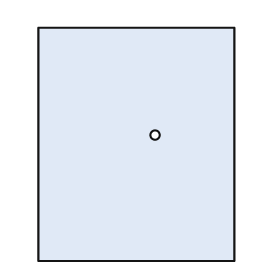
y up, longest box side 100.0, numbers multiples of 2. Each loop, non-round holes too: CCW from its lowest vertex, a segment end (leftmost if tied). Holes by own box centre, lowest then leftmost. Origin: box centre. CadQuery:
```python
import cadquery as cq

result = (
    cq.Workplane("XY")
    .moveTo(-42.0, -50.0)
    .lineTo(42.0, -50.0)
    .lineTo(42.0, 50.0)
    .lineTo(-42.0, 50.0)
    .close()
    .moveTo(8.0, 4.0)
    .circle(2.0)
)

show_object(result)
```